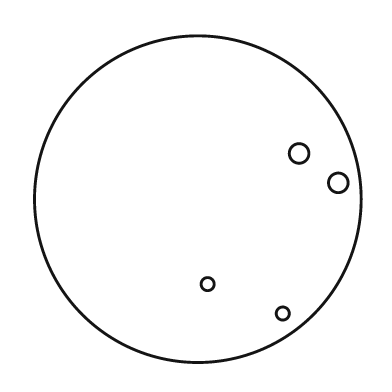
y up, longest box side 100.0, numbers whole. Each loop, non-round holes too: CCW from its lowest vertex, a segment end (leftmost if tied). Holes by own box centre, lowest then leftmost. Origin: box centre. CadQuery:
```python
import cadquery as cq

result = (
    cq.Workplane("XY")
    .moveTo(0.0, 0.0)
    .circle(50.0)
    .moveTo(26.0, -35.0)
    .circle(2.0)
    .moveTo(3.0, -26.0)
    .circle(2.0)
    .moveTo(43.0, 5.0)
    .circle(3.0)
    .moveTo(31.0, 14.0)
    .circle(3.0)
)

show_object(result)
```